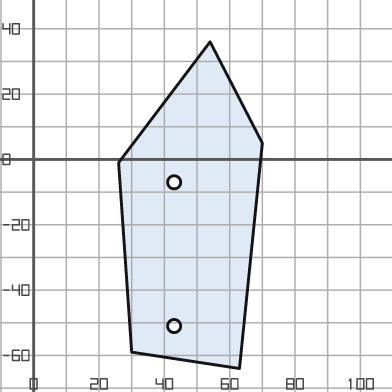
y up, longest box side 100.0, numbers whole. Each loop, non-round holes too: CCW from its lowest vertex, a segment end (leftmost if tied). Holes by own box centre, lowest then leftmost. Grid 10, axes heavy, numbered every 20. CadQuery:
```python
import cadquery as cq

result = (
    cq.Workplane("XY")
    .moveTo(63.0, -64.0)
    .lineTo(70.0, 5.0)
    .lineTo(54.0, 36.0)
    .lineTo(26.0, -1.0)
    .lineTo(30.0, -59.0)
    .close()
    .moveTo(43.0, -51.0)
    .circle(2.0)
    .moveTo(43.0, -7.0)
    .circle(2.0)
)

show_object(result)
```